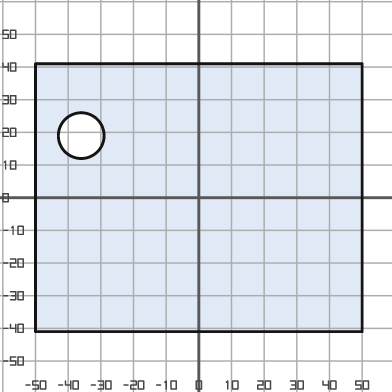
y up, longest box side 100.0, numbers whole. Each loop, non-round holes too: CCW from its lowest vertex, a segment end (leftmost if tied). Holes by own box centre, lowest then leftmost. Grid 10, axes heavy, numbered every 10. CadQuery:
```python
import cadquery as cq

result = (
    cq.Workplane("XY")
    .moveTo(-50.0, -41.0)
    .lineTo(50.0, -41.0)
    .lineTo(50.0, 41.0)
    .lineTo(-50.0, 41.0)
    .close()
    .moveTo(-36.0, 19.0)
    .circle(7.0)
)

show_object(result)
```